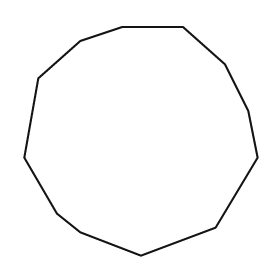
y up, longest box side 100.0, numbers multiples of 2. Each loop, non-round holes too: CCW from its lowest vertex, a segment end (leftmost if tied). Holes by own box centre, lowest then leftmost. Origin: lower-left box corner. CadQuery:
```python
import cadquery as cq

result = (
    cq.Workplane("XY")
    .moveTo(50.0, 0.0)
    .lineTo(82.0, 12.0)
    .lineTo(100.0, 42.0)
    .lineTo(96.0, 62.0)
    .lineTo(86.0, 82.0)
    .lineTo(68.0, 98.0)
    .lineTo(42.0, 98.0)
    .lineTo(24.0, 92.0)
    .lineTo(6.0, 76.0)
    .lineTo(0.0, 42.0)
    .lineTo(14.0, 18.0)
    .lineTo(24.0, 10.0)
    .close()
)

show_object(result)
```